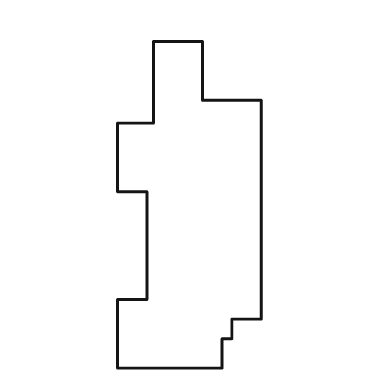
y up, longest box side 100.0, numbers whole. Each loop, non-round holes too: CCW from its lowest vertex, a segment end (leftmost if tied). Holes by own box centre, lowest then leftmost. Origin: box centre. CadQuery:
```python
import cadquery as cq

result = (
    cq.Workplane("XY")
    .moveTo(-22.0, -50.0)
    .lineTo(10.0, -50.0)
    .lineTo(10.0, -41.0)
    .lineTo(13.0, -41.0)
    .lineTo(13.0, -35.0)
    .lineTo(22.0, -35.0)
    .lineTo(22.0, 32.0)
    .lineTo(4.0, 32.0)
    .lineTo(4.0, 50.0)
    .lineTo(-11.0, 50.0)
    .lineTo(-11.0, 25.0)
    .lineTo(-22.0, 25.0)
    .lineTo(-22.0, 4.0)
    .lineTo(-13.0, 4.0)
    .lineTo(-13.0, -29.0)
    .lineTo(-22.0, -29.0)
    .close()
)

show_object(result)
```